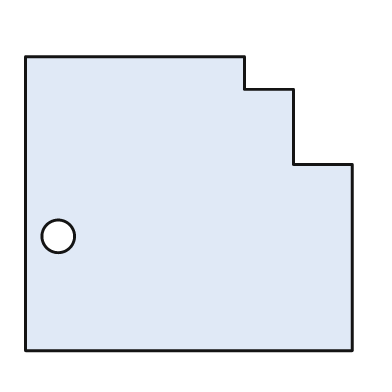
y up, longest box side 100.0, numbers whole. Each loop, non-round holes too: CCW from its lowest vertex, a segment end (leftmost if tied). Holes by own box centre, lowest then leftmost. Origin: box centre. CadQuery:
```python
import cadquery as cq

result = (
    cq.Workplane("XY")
    .moveTo(-50.0, -45.0)
    .lineTo(50.0, -45.0)
    .lineTo(50.0, 12.0)
    .lineTo(32.0, 12.0)
    .lineTo(32.0, 35.0)
    .lineTo(17.0, 35.0)
    .lineTo(17.0, 45.0)
    .lineTo(-50.0, 45.0)
    .close()
    .moveTo(-40.0, -10.0)
    .circle(5.0)
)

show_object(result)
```